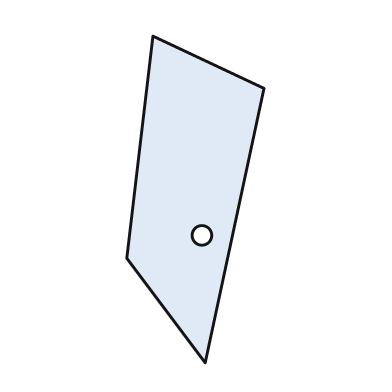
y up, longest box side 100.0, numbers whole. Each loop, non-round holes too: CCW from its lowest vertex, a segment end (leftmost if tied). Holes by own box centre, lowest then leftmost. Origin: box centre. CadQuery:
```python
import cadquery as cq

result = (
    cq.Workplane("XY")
    .moveTo(3.0, -50.0)
    .lineTo(21.0, 34.0)
    .lineTo(-13.0, 50.0)
    .lineTo(-21.0, -18.0)
    .close()
    .moveTo(2.0, -11.0)
    .circle(3.0)
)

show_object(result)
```